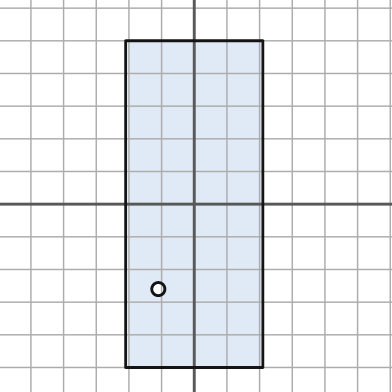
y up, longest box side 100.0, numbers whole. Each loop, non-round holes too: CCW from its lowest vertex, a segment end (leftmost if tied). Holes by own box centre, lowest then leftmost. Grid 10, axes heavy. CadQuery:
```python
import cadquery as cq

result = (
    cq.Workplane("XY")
    .moveTo(-21.0, -50.0)
    .lineTo(21.0, -50.0)
    .lineTo(21.0, 50.0)
    .lineTo(-21.0, 50.0)
    .close()
    .moveTo(-11.0, -26.0)
    .circle(2.0)
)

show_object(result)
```